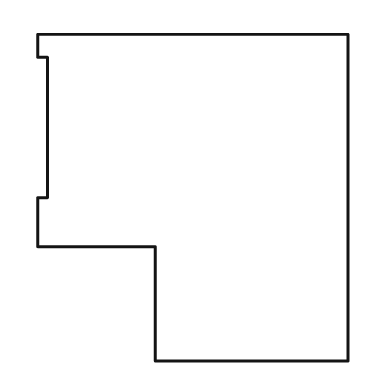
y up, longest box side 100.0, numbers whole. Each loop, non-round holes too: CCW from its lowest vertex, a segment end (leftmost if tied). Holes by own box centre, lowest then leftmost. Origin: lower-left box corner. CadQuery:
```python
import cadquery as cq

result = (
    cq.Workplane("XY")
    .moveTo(36.0, 0.0)
    .lineTo(95.0, 0.0)
    .lineTo(95.0, 100.0)
    .lineTo(0.0, 100.0)
    .lineTo(0.0, 93.0)
    .lineTo(3.0, 93.0)
    .lineTo(3.0, 50.0)
    .lineTo(0.0, 50.0)
    .lineTo(0.0, 35.0)
    .lineTo(36.0, 35.0)
    .close()
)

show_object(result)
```